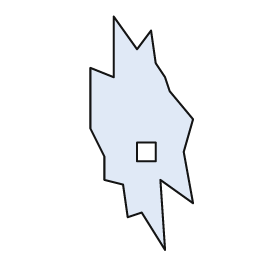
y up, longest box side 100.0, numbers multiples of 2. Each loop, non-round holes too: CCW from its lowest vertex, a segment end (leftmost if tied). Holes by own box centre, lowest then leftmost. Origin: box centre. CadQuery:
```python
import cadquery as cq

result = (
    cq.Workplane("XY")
    .moveTo(10.0, -50.0)
    .lineTo(8.0, -20.0)
    .lineTo(22.0, -30.0)
    .lineTo(18.0, -8.0)
    .lineTo(22.0, 6.0)
    .lineTo(12.0, 18.0)
    .lineTo(10.0, 24.0)
    .lineTo(6.0, 30.0)
    .lineTo(4.0, 44.0)
    .lineTo(-2.0, 36.0)
    .lineTo(-12.0, 50.0)
    .lineTo(-12.0, 24.0)
    .lineTo(-22.0, 28.0)
    .lineTo(-22.0, 2.0)
    .lineTo(-16.0, -10.0)
    .lineTo(-16.0, -20.0)
    .lineTo(-8.0, -22.0)
    .lineTo(-6.0, -36.0)
    .lineTo(0.0, -34.0)
    .close()
    .moveTo(-2.0, -12.0)
    .lineTo(6.0, -12.0)
    .lineTo(6.0, -4.0)
    .lineTo(-2.0, -4.0)
    .close()
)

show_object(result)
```